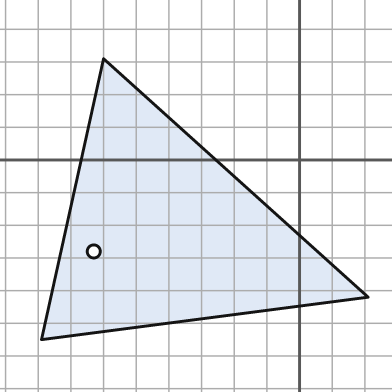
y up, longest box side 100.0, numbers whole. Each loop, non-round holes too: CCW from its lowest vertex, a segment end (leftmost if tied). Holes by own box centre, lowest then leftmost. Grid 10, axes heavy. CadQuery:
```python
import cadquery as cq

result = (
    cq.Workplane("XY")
    .moveTo(-79.0, -55.0)
    .lineTo(21.0, -42.0)
    .lineTo(-60.0, 31.0)
    .close()
    .moveTo(-63.0, -28.0)
    .circle(2.0)
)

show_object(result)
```